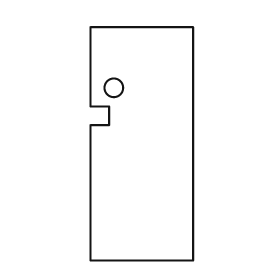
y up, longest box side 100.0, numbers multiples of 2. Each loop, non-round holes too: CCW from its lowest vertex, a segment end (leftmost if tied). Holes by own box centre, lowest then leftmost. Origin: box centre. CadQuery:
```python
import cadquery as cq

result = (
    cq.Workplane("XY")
    .moveTo(-22.0, -50.0)
    .lineTo(22.0, -50.0)
    .lineTo(22.0, 50.0)
    .lineTo(-22.0, 50.0)
    .lineTo(-22.0, 16.0)
    .lineTo(-14.0, 16.0)
    .lineTo(-14.0, 8.0)
    .lineTo(-22.0, 8.0)
    .close()
    .moveTo(-12.0, 24.0)
    .circle(4.0)
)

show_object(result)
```